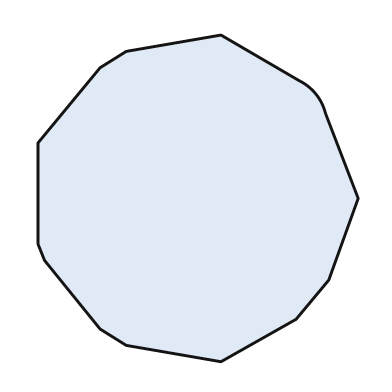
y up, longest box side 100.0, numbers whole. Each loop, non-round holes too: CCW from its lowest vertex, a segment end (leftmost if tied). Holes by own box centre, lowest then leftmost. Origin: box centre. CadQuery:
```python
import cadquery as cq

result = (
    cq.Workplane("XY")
    .moveTo(7.0, -50.0)
    .lineTo(30.0, -37.0)
    .lineTo(40.0, -25.0)
    .lineTo(49.0, 0.0)
    .lineTo(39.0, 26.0)
    .threePointArc((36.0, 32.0), (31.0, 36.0))
    .lineTo(7.0, 50.0)
    .lineTo(-22.0, 45.0)
    .lineTo(-30.0, 40.0)
    .lineTo(-49.0, 17.0)
    .lineTo(-49.0, -14.0)
    .lineTo(-47.0, -19.0)
    .lineTo(-30.0, -40.0)
    .lineTo(-22.0, -45.0)
    .close()
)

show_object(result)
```